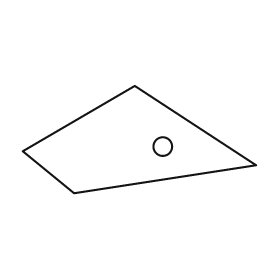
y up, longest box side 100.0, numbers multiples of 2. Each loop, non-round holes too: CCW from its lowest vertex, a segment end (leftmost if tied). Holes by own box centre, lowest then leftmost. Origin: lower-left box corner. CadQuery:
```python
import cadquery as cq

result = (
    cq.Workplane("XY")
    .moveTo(22.0, 0.0)
    .lineTo(100.0, 12.0)
    .lineTo(48.0, 46.0)
    .lineTo(0.0, 18.0)
    .close()
    .moveTo(60.0, 20.0)
    .circle(4.0)
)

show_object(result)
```